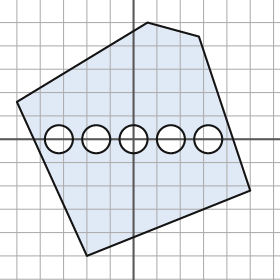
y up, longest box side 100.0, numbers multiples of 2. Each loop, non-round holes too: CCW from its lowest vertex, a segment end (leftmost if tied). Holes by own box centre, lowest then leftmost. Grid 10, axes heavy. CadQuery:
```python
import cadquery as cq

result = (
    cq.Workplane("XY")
    .moveTo(-20.0, -50.0)
    .lineTo(50.0, -22.0)
    .lineTo(28.0, 44.0)
    .lineTo(6.0, 50.0)
    .lineTo(-50.0, 16.0)
    .close()
    .moveTo(-32.0, 0.0)
    .circle(6.0)
    .moveTo(-16.0, 0.0)
    .circle(6.0)
    .moveTo(0.0, 0.0)
    .circle(6.0)
    .moveTo(16.0, 0.0)
    .circle(6.0)
    .moveTo(32.0, 0.0)
    .circle(6.0)
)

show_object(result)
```